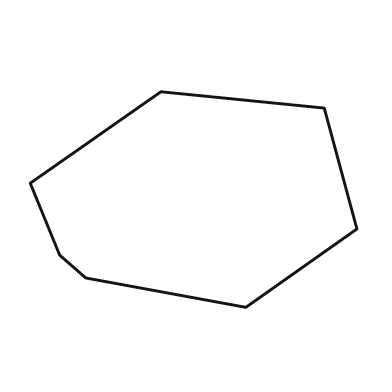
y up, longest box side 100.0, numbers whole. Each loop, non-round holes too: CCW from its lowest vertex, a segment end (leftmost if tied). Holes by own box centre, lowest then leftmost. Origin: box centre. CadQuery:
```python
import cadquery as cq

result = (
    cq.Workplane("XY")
    .moveTo(16.0, -33.0)
    .lineTo(50.0, -9.0)
    .lineTo(40.0, 28.0)
    .lineTo(-10.0, 33.0)
    .lineTo(-50.0, 5.0)
    .lineTo(-41.0, -17.0)
    .lineTo(-33.0, -24.0)
    .close()
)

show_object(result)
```